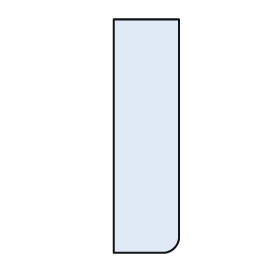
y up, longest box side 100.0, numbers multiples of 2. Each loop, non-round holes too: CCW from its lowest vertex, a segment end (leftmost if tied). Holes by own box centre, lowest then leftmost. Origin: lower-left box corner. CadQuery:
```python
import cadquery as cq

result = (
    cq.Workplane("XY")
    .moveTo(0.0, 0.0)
    .lineTo(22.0, 0.0)
    .threePointArc((26.0, 2.0), (28.0, 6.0))
    .lineTo(28.0, 100.0)
    .lineTo(0.0, 100.0)
    .close()
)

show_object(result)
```